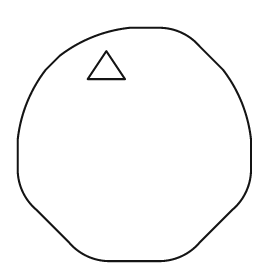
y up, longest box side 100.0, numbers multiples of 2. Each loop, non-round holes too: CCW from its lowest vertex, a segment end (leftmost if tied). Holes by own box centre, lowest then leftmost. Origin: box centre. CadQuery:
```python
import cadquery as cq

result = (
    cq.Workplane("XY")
    .moveTo(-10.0, -50.0)
    .lineTo(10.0, -50.0)
    .threePointArc((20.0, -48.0), (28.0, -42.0))
    .lineTo(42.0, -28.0)
    .threePointArc((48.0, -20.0), (50.0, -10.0))
    .lineTo(50.0, 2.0)
    .threePointArc((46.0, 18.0), (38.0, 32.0))
    .lineTo(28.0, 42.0)
    .threePointArc((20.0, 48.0), (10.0, 50.0))
    .lineTo(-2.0, 50.0)
    .threePointArc((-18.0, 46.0), (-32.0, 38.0))
    .lineTo(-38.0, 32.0)
    .threePointArc((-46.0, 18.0), (-50.0, 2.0))
    .lineTo(-50.0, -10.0)
    .threePointArc((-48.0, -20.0), (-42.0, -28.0))
    .lineTo(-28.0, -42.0)
    .threePointArc((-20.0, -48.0), (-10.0, -50.0))
    .close()
    .moveTo(-20.0, 28.0)
    .lineTo(-4.0, 28.0)
    .lineTo(-12.0, 40.0)
    .close()
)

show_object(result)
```